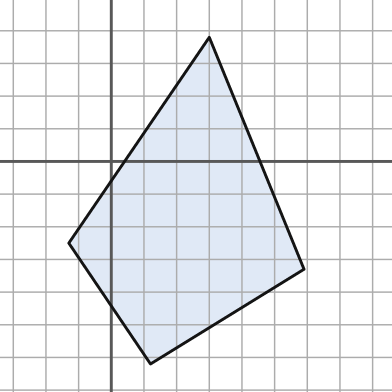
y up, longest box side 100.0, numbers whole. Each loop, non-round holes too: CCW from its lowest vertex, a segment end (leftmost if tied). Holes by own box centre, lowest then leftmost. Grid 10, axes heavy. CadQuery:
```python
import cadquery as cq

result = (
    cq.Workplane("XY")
    .moveTo(12.0, -62.0)
    .lineTo(59.0, -33.0)
    .lineTo(30.0, 38.0)
    .lineTo(-13.0, -25.0)
    .close()
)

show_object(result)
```